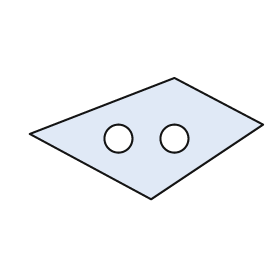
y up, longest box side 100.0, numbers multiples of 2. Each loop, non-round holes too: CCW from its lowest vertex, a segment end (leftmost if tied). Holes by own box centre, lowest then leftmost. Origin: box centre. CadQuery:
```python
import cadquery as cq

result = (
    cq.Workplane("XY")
    .moveTo(2.0, -26.0)
    .lineTo(50.0, 6.0)
    .lineTo(12.0, 26.0)
    .lineTo(-50.0, 2.0)
    .close()
    .moveTo(-12.0, 0.0)
    .circle(6.0)
    .moveTo(12.0, 0.0)
    .circle(6.0)
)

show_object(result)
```